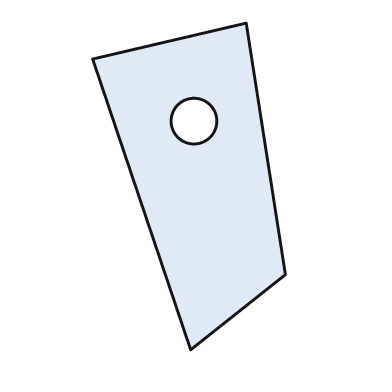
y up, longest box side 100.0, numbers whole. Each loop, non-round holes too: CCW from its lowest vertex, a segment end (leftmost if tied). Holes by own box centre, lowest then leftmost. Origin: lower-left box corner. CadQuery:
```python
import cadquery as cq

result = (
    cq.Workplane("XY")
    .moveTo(30.0, 0.0)
    .lineTo(59.0, 23.0)
    .lineTo(47.0, 100.0)
    .lineTo(0.0, 89.0)
    .close()
    .moveTo(31.0, 70.0)
    .circle(7.0)
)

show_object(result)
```